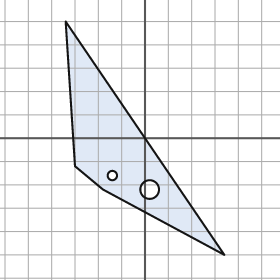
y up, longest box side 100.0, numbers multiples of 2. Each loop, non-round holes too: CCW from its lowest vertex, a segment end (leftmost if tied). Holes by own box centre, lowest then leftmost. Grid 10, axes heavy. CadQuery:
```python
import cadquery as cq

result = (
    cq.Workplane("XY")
    .moveTo(34.0, -50.0)
    .lineTo(-34.0, 50.0)
    .lineTo(-30.0, -12.0)
    .lineTo(-18.0, -22.0)
    .close()
    .moveTo(2.0, -22.0)
    .circle(4.0)
    .moveTo(-14.0, -16.0)
    .circle(2.0)
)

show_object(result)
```